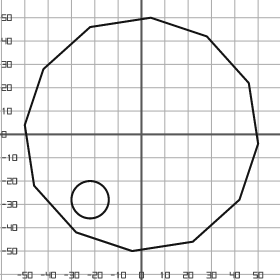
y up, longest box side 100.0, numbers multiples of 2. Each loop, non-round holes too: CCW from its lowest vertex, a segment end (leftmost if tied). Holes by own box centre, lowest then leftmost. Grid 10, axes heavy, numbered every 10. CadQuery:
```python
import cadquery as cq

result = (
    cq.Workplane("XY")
    .moveTo(-4.0, -50.0)
    .lineTo(22.0, -46.0)
    .lineTo(42.0, -28.0)
    .lineTo(50.0, -4.0)
    .lineTo(46.0, 22.0)
    .lineTo(28.0, 42.0)
    .lineTo(4.0, 50.0)
    .lineTo(-22.0, 46.0)
    .lineTo(-42.0, 28.0)
    .lineTo(-50.0, 4.0)
    .lineTo(-46.0, -22.0)
    .lineTo(-28.0, -42.0)
    .close()
    .moveTo(-22.0, -28.0)
    .circle(8.0)
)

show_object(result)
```